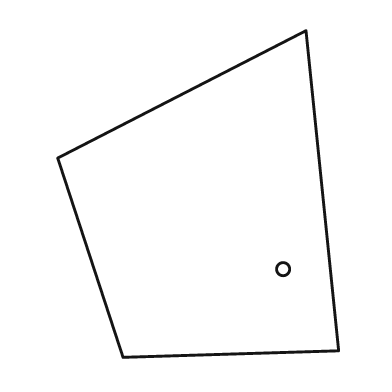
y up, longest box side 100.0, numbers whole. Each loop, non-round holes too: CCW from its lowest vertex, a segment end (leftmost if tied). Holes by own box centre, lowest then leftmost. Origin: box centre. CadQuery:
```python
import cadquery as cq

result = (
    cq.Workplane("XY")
    .moveTo(-23.0, -50.0)
    .lineTo(43.0, -48.0)
    .lineTo(33.0, 50.0)
    .lineTo(-43.0, 11.0)
    .close()
    .moveTo(26.0, -23.0)
    .circle(2.0)
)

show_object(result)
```